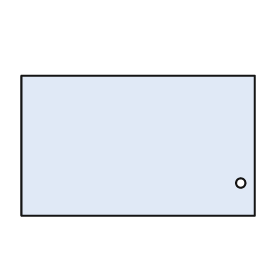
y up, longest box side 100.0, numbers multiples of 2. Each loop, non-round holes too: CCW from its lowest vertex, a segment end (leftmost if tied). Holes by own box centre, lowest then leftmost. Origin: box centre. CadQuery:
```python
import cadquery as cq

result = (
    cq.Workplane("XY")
    .moveTo(-50.0, -30.0)
    .lineTo(50.0, -30.0)
    .lineTo(50.0, 30.0)
    .lineTo(-50.0, 30.0)
    .close()
    .moveTo(44.0, -16.0)
    .circle(2.0)
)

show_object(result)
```